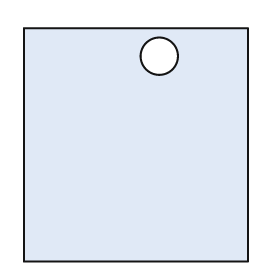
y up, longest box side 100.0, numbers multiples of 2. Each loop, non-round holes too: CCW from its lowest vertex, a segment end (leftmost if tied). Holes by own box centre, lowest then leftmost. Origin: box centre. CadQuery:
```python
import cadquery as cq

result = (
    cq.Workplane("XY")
    .moveTo(-48.0, -50.0)
    .lineTo(48.0, -50.0)
    .lineTo(48.0, 50.0)
    .lineTo(-48.0, 50.0)
    .close()
    .moveTo(10.0, 38.0)
    .circle(8.0)
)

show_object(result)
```